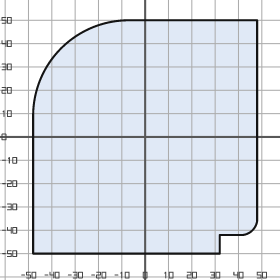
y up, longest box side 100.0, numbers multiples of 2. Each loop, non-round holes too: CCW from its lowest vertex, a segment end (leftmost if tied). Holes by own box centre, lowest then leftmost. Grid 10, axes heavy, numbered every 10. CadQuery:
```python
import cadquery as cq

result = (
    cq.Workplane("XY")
    .moveTo(-48.0, -50.0)
    .lineTo(32.0, -50.0)
    .lineTo(32.0, -42.0)
    .lineTo(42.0, -42.0)
    .threePointArc((46.0, -40.0), (48.0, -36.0))
    .lineTo(48.0, 50.0)
    .lineTo(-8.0, 50.0)
    .threePointArc((-36.0, 38.0), (-48.0, 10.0))
    .close()
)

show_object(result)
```